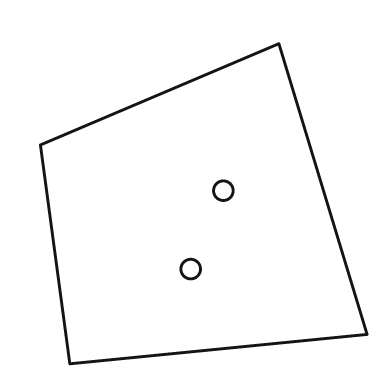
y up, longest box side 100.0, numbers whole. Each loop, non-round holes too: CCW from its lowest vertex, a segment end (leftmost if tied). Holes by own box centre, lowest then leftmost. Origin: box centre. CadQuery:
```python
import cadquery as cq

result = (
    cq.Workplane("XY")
    .moveTo(-41.0, -49.0)
    .lineTo(50.0, -40.0)
    .lineTo(23.0, 49.0)
    .lineTo(-50.0, 18.0)
    .close()
    .moveTo(-4.0, -20.0)
    .circle(3.0)
    .moveTo(6.0, 4.0)
    .circle(3.0)
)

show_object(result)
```